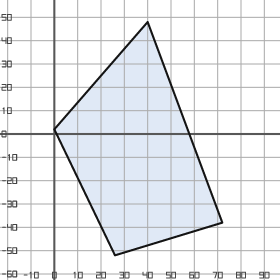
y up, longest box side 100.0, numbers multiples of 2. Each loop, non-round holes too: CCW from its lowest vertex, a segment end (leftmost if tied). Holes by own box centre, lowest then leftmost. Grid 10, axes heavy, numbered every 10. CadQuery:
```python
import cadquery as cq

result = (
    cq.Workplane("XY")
    .moveTo(26.0, -52.0)
    .lineTo(72.0, -38.0)
    .lineTo(40.0, 48.0)
    .lineTo(0.0, 2.0)
    .close()
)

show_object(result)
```